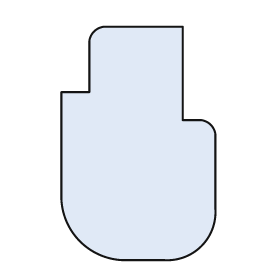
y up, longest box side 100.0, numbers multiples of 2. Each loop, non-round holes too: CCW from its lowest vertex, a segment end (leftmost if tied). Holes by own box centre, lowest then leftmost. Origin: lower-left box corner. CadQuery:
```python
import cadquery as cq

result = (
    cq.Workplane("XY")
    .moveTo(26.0, 0.0)
    .lineTo(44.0, 0.0)
    .threePointArc((60.0, 6.0), (66.0, 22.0))
    .lineTo(66.0, 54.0)
    .threePointArc((64.0, 58.0), (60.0, 60.0))
    .lineTo(52.0, 60.0)
    .lineTo(52.0, 100.0)
    .lineTo(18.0, 100.0)
    .threePointArc((14.0, 98.0), (12.0, 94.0))
    .lineTo(12.0, 72.0)
    .lineTo(0.0, 72.0)
    .lineTo(0.0, 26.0)
    .threePointArc((8.0, 8.0), (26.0, 0.0))
    .close()
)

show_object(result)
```